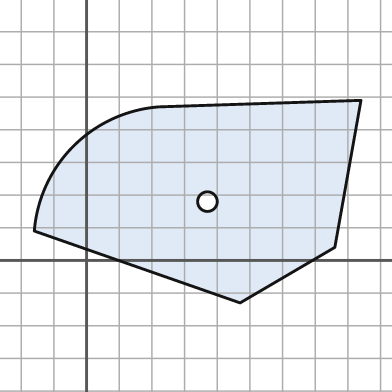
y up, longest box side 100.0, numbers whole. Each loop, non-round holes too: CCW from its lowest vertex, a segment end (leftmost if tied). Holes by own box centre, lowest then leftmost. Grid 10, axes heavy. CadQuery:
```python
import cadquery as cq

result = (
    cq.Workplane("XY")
    .moveTo(47.0, -13.0)
    .lineTo(76.0, 4.0)
    .lineTo(84.0, 49.0)
    .lineTo(22.0, 47.0)
    .threePointArc((-4.0, 35.0), (-16.0, 9.0))
    .close()
    .moveTo(37.0, 18.0)
    .circle(3.0)
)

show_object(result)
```